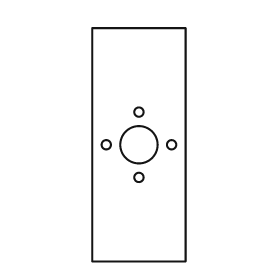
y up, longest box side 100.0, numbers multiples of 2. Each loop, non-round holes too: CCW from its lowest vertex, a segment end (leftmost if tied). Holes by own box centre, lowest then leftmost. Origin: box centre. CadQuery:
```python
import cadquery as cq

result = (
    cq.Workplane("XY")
    .moveTo(-20.0, -50.0)
    .lineTo(20.0, -50.0)
    .lineTo(20.0, 50.0)
    .lineTo(-20.0, 50.0)
    .close()
    .moveTo(0.0, -14.0)
    .circle(2.0)
    .moveTo(-14.0, 0.0)
    .circle(2.0)
    .moveTo(0.0, 0.0)
    .circle(8.0)
    .moveTo(14.0, 0.0)
    .circle(2.0)
    .moveTo(0.0, 14.0)
    .circle(2.0)
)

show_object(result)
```